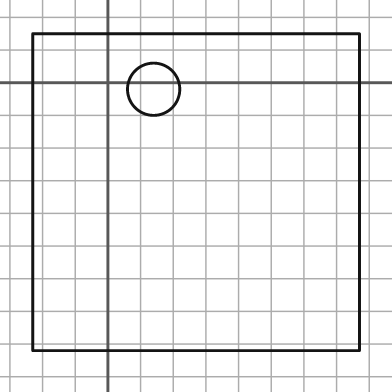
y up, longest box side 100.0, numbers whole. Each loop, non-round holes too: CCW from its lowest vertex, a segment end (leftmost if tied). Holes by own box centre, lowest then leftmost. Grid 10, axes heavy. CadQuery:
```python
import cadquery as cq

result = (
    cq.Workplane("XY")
    .moveTo(-23.0, -82.0)
    .lineTo(77.0, -82.0)
    .lineTo(77.0, 15.0)
    .lineTo(-23.0, 15.0)
    .close()
    .moveTo(14.0, -2.0)
    .circle(8.0)
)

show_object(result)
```